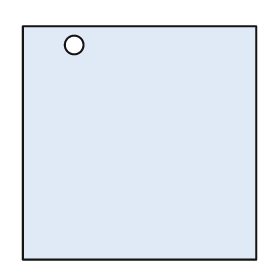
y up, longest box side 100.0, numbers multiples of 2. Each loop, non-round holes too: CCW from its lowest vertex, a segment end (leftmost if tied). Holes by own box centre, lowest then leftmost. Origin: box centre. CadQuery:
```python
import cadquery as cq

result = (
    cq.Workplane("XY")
    .moveTo(-50.0, -50.0)
    .lineTo(50.0, -50.0)
    .lineTo(50.0, 50.0)
    .lineTo(-50.0, 50.0)
    .close()
    .moveTo(-28.0, 42.0)
    .circle(4.0)
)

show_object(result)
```